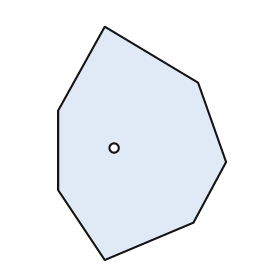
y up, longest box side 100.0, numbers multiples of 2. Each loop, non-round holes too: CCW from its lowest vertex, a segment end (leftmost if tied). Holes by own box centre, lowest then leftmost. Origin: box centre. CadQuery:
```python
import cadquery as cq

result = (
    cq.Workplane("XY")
    .moveTo(-16.0, -50.0)
    .lineTo(22.0, -34.0)
    .lineTo(36.0, -8.0)
    .lineTo(24.0, 26.0)
    .lineTo(-16.0, 50.0)
    .lineTo(-36.0, 14.0)
    .lineTo(-36.0, -20.0)
    .close()
    .moveTo(-12.0, -2.0)
    .circle(2.0)
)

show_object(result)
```